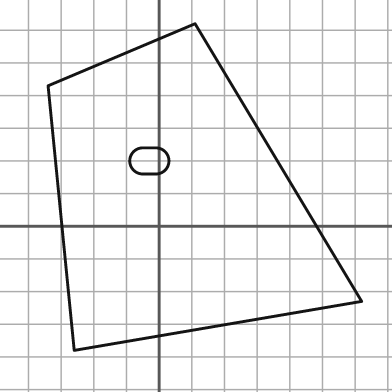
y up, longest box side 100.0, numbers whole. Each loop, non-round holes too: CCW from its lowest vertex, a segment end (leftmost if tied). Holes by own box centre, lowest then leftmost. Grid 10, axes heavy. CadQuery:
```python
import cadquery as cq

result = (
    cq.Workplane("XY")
    .moveTo(-26.0, -38.0)
    .lineTo(62.0, -23.0)
    .lineTo(11.0, 62.0)
    .lineTo(-34.0, 43.0)
    .close()
    .moveTo(-5.0, 16.0)
    .lineTo(-1.0, 16.0)
    .threePointArc((3.0, 20.0), (-1.0, 24.0))
    .lineTo(-5.0, 24.0)
    .threePointArc((-9.0, 20.0), (-5.0, 16.0))
    .close()
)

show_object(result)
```